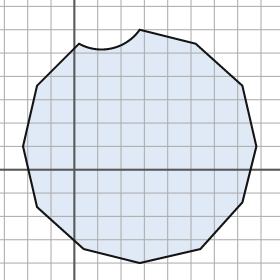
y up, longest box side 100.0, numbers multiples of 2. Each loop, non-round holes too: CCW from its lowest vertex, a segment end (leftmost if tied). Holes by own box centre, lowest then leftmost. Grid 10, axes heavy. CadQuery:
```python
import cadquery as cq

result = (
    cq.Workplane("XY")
    .moveTo(28.0, -40.0)
    .lineTo(54.0, -34.0)
    .lineTo(72.0, -14.0)
    .lineTo(78.0, 10.0)
    .lineTo(72.0, 36.0)
    .lineTo(52.0, 54.0)
    .lineTo(28.0, 60.0)
    .threePointArc((16.0, 52.0), (2.0, 54.0))
    .lineTo(-16.0, 36.0)
    .lineTo(-22.0, 10.0)
    .lineTo(-16.0, -16.0)
    .lineTo(4.0, -34.0)
    .close()
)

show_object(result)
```